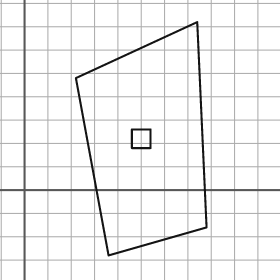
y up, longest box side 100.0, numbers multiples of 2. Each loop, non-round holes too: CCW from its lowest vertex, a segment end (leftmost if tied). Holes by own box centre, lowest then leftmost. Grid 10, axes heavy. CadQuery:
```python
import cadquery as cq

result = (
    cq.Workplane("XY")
    .moveTo(36.0, -28.0)
    .lineTo(78.0, -16.0)
    .lineTo(74.0, 72.0)
    .lineTo(22.0, 48.0)
    .close()
    .moveTo(46.0, 18.0)
    .lineTo(54.0, 18.0)
    .lineTo(54.0, 26.0)
    .lineTo(46.0, 26.0)
    .close()
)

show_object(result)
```